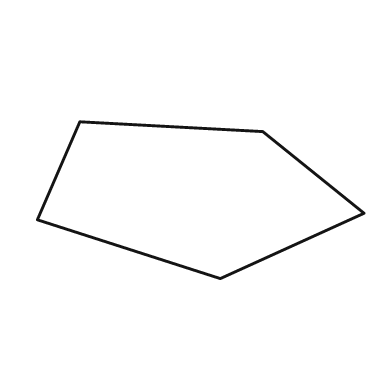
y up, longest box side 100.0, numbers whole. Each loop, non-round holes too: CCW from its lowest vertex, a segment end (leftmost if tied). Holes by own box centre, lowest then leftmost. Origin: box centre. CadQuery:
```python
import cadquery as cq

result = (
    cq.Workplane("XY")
    .moveTo(6.0, -24.0)
    .lineTo(50.0, -4.0)
    .lineTo(19.0, 21.0)
    .lineTo(-37.0, 24.0)
    .lineTo(-50.0, -6.0)
    .close()
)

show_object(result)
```